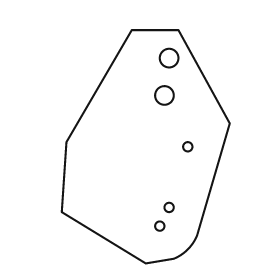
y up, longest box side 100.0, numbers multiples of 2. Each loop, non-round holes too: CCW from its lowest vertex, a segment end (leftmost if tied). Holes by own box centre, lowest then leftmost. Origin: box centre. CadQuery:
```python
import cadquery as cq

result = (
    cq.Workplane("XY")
    .moveTo(0.0, -50.0)
    .lineTo(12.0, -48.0)
    .threePointArc((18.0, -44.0), (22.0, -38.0))
    .lineTo(36.0, 10.0)
    .lineTo(14.0, 50.0)
    .lineTo(-6.0, 50.0)
    .lineTo(-34.0, 2.0)
    .lineTo(-36.0, -28.0)
    .close()
    .moveTo(6.0, -34.0)
    .circle(2.0)
    .moveTo(10.0, -26.0)
    .circle(2.0)
    .moveTo(18.0, 0.0)
    .circle(2.0)
    .moveTo(8.0, 22.0)
    .circle(4.0)
    .moveTo(10.0, 38.0)
    .circle(4.0)
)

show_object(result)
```